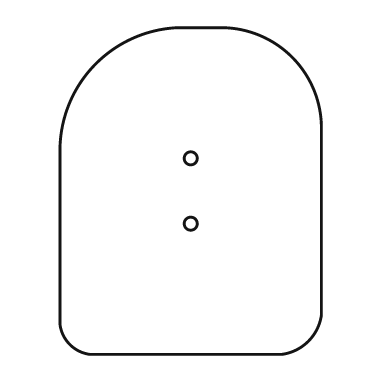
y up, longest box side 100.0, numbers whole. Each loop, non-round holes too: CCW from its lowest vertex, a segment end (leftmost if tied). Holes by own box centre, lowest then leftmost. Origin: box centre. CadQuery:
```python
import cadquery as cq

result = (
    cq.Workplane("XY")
    .moveTo(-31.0, -50.0)
    .lineTo(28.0, -50.0)
    .threePointArc((36.0, -46.0), (40.0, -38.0))
    .lineTo(40.0, 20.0)
    .threePointArc((31.0, 41.0), (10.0, 50.0))
    .lineTo(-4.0, 50.0)
    .threePointArc((-29.0, 39.0), (-40.0, 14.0))
    .lineTo(-40.0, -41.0)
    .threePointArc((-37.0, -47.0), (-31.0, -50.0))
    .close()
    .moveTo(0.0, -10.0)
    .circle(2.0)
    .moveTo(0.0, 10.0)
    .circle(2.0)
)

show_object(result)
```